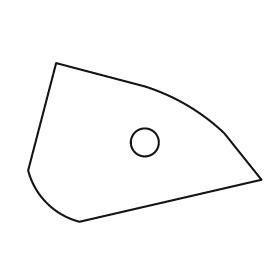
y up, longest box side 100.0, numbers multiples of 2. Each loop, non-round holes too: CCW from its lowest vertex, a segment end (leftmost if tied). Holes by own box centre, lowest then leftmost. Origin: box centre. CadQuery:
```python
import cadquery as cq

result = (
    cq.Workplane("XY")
    .moveTo(-28.0, -34.0)
    .lineTo(50.0, -16.0)
    .lineTo(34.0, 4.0)
    .threePointArc((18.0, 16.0), (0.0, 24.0))
    .lineTo(-38.0, 34.0)
    .lineTo(-50.0, -12.0)
    .threePointArc((-42.0, -26.0), (-28.0, -34.0))
    .close()
    .moveTo(0.0, 0.0)
    .circle(6.0)
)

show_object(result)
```